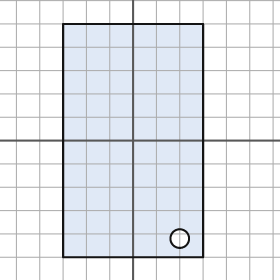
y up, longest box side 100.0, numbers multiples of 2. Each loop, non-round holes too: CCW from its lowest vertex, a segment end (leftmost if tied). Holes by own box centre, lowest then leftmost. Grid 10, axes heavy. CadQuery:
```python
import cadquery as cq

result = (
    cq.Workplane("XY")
    .moveTo(-30.0, -50.0)
    .lineTo(30.0, -50.0)
    .lineTo(30.0, 50.0)
    .lineTo(-30.0, 50.0)
    .close()
    .moveTo(20.0, -42.0)
    .circle(4.0)
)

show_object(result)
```